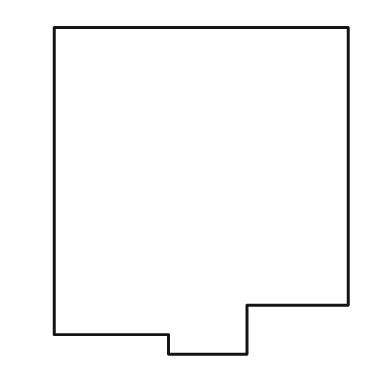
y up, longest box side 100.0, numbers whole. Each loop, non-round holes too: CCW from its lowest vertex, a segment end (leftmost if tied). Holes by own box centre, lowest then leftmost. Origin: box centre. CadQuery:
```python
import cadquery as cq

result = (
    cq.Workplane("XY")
    .moveTo(-10.0, -50.0)
    .lineTo(14.0, -50.0)
    .lineTo(14.0, -35.0)
    .lineTo(45.0, -35.0)
    .lineTo(45.0, 50.0)
    .lineTo(-45.0, 50.0)
    .lineTo(-45.0, -44.0)
    .lineTo(-10.0, -44.0)
    .close()
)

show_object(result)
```